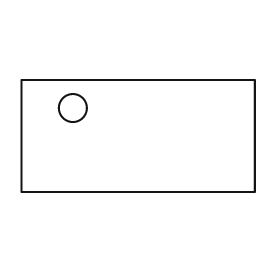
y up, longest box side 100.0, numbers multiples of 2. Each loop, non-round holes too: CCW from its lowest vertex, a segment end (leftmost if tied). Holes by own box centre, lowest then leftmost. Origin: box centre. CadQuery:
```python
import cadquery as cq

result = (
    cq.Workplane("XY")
    .moveTo(-50.0, -24.0)
    .lineTo(50.0, -24.0)
    .lineTo(50.0, 24.0)
    .lineTo(-50.0, 24.0)
    .close()
    .moveTo(-28.0, 12.0)
    .circle(6.0)
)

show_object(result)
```